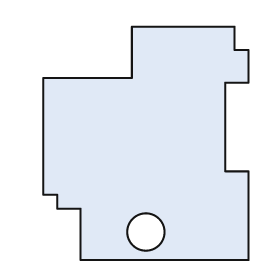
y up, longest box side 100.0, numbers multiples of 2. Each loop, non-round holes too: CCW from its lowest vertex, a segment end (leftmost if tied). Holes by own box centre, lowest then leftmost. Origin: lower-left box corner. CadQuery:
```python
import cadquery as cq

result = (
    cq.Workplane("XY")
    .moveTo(16.0, 0.0)
    .lineTo(88.0, 0.0)
    .lineTo(88.0, 38.0)
    .lineTo(78.0, 38.0)
    .lineTo(78.0, 76.0)
    .lineTo(88.0, 76.0)
    .lineTo(88.0, 90.0)
    .lineTo(82.0, 90.0)
    .lineTo(82.0, 100.0)
    .lineTo(38.0, 100.0)
    .lineTo(38.0, 78.0)
    .lineTo(0.0, 78.0)
    .lineTo(0.0, 28.0)
    .lineTo(6.0, 28.0)
    .lineTo(6.0, 22.0)
    .lineTo(16.0, 22.0)
    .close()
    .moveTo(44.0, 12.0)
    .circle(8.0)
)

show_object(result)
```